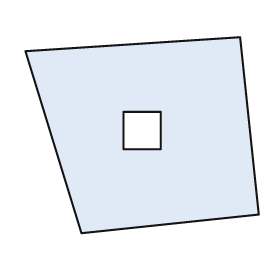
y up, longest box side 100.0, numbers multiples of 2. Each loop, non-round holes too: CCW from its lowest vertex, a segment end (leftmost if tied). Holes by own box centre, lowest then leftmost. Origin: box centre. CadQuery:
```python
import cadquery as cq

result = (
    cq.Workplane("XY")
    .moveTo(-26.0, -42.0)
    .lineTo(50.0, -34.0)
    .lineTo(42.0, 42.0)
    .lineTo(-50.0, 36.0)
    .close()
    .moveTo(-8.0, -6.0)
    .lineTo(8.0, -6.0)
    .lineTo(8.0, 10.0)
    .lineTo(-8.0, 10.0)
    .close()
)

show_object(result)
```